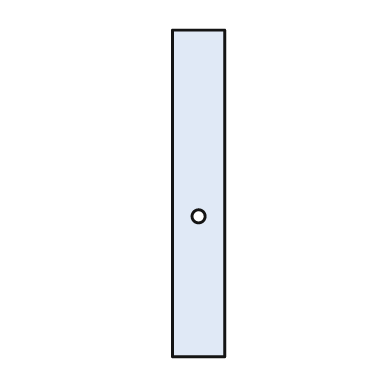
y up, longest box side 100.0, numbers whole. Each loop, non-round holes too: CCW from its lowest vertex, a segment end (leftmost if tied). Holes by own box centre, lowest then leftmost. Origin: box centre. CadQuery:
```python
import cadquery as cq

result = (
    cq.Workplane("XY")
    .moveTo(-8.0, -50.0)
    .lineTo(8.0, -50.0)
    .lineTo(8.0, 50.0)
    .lineTo(-8.0, 50.0)
    .close()
    .moveTo(0.0, -7.0)
    .circle(2.0)
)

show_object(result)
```